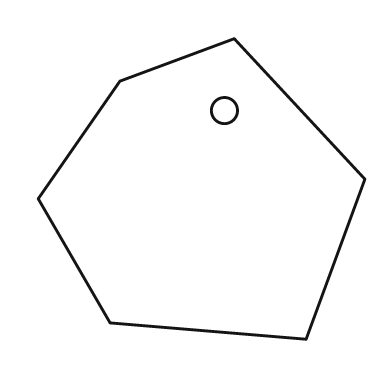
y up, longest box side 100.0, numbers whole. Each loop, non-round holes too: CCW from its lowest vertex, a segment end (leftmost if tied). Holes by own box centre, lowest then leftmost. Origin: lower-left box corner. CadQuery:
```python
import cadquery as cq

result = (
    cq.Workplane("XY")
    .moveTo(82.0, 0.0)
    .lineTo(100.0, 49.0)
    .lineTo(60.0, 92.0)
    .lineTo(25.0, 79.0)
    .lineTo(0.0, 43.0)
    .lineTo(22.0, 5.0)
    .close()
    .moveTo(57.0, 70.0)
    .circle(4.0)
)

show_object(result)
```